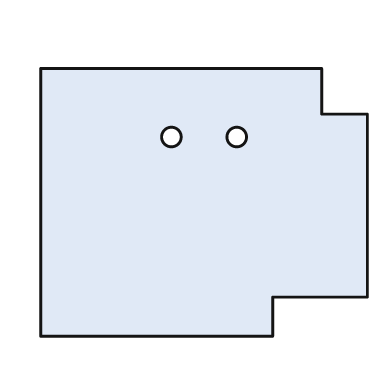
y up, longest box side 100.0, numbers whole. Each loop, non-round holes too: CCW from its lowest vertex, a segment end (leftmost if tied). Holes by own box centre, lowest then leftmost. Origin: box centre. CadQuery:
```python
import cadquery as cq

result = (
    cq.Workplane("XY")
    .moveTo(-50.0, -41.0)
    .lineTo(21.0, -41.0)
    .lineTo(21.0, -29.0)
    .lineTo(50.0, -29.0)
    .lineTo(50.0, 27.0)
    .lineTo(36.0, 27.0)
    .lineTo(36.0, 41.0)
    .lineTo(-50.0, 41.0)
    .close()
    .moveTo(-10.0, 20.0)
    .circle(3.0)
    .moveTo(10.0, 20.0)
    .circle(3.0)
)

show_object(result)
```